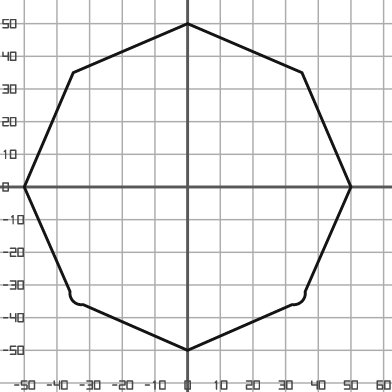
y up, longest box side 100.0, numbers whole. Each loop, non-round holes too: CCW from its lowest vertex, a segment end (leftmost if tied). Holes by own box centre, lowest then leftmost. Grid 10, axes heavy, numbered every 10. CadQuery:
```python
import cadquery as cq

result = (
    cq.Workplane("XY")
    .moveTo(0.0, -50.0)
    .lineTo(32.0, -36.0)
    .threePointArc((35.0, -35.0), (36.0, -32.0))
    .lineTo(50.0, 0.0)
    .lineTo(35.0, 35.0)
    .lineTo(0.0, 50.0)
    .lineTo(-35.0, 35.0)
    .lineTo(-50.0, 0.0)
    .lineTo(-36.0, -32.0)
    .threePointArc((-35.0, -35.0), (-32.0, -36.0))
    .close()
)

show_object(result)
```